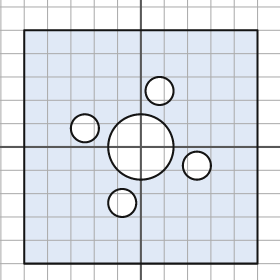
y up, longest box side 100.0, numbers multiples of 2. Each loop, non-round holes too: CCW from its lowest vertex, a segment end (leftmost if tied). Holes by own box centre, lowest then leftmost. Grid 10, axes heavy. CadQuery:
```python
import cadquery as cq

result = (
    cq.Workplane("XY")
    .moveTo(-50.0, -50.0)
    .lineTo(50.0, -50.0)
    .lineTo(50.0, 50.0)
    .lineTo(-50.0, 50.0)
    .close()
    .moveTo(-8.0, -24.0)
    .circle(6.0)
    .moveTo(24.0, -8.0)
    .circle(6.0)
    .moveTo(0.0, 0.0)
    .circle(14.0)
    .moveTo(-24.0, 8.0)
    .circle(6.0)
    .moveTo(8.0, 24.0)
    .circle(6.0)
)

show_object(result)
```